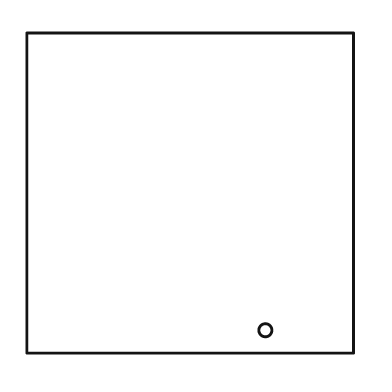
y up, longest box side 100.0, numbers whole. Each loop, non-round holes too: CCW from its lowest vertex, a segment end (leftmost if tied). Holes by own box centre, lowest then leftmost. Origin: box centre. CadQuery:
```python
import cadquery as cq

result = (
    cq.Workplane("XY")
    .moveTo(-50.0, -49.0)
    .lineTo(50.0, -49.0)
    .lineTo(50.0, 49.0)
    .lineTo(-50.0, 49.0)
    .close()
    .moveTo(23.0, -42.0)
    .circle(2.0)
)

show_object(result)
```